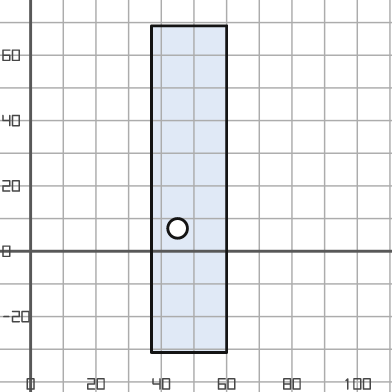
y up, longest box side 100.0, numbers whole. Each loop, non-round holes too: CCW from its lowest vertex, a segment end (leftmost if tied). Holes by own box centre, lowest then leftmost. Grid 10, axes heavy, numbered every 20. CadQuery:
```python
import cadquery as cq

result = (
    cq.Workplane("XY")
    .moveTo(37.0, -31.0)
    .lineTo(60.0, -31.0)
    .lineTo(60.0, 69.0)
    .lineTo(37.0, 69.0)
    .close()
    .moveTo(45.0, 7.0)
    .circle(3.0)
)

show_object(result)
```